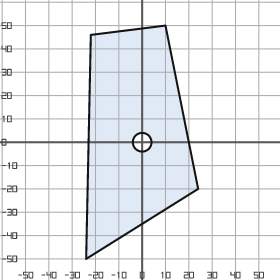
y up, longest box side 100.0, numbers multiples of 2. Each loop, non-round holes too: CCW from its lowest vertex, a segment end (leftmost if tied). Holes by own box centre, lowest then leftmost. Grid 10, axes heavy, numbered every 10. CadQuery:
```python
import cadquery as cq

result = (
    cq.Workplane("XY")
    .moveTo(-24.0, -50.0)
    .lineTo(24.0, -20.0)
    .lineTo(10.0, 50.0)
    .lineTo(-22.0, 46.0)
    .close()
    .moveTo(0.0, 0.0)
    .circle(4.0)
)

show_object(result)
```